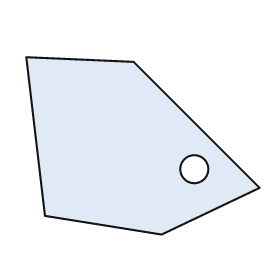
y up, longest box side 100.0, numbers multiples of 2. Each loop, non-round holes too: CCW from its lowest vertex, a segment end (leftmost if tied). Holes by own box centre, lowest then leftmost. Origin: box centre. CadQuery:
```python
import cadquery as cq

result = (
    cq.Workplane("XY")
    .moveTo(8.0, -38.0)
    .lineTo(50.0, -18.0)
    .lineTo(-4.0, 36.0)
    .lineTo(-50.0, 38.0)
    .lineTo(-42.0, -30.0)
    .close()
    .moveTo(22.0, -10.0)
    .circle(6.0)
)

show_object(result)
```